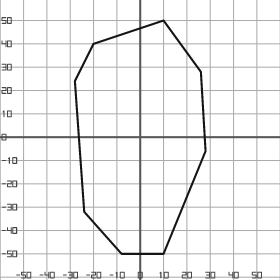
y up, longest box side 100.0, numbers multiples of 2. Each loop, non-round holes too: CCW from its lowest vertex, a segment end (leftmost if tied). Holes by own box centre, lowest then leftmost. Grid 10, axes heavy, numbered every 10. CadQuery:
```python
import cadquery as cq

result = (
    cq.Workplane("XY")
    .moveTo(-8.0, -50.0)
    .lineTo(10.0, -50.0)
    .lineTo(28.0, -6.0)
    .lineTo(26.0, 28.0)
    .lineTo(10.0, 50.0)
    .lineTo(-20.0, 40.0)
    .lineTo(-28.0, 24.0)
    .lineTo(-24.0, -32.0)
    .close()
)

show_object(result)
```